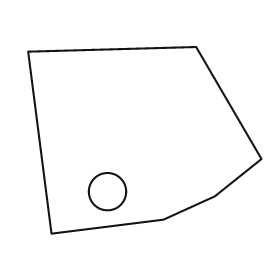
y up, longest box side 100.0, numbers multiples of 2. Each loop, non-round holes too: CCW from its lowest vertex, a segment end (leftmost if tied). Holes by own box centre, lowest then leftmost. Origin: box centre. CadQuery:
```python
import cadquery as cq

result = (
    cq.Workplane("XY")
    .moveTo(-40.0, -40.0)
    .lineTo(8.0, -34.0)
    .lineTo(30.0, -24.0)
    .lineTo(50.0, -8.0)
    .lineTo(22.0, 40.0)
    .lineTo(-50.0, 38.0)
    .close()
    .moveTo(-16.0, -22.0)
    .circle(8.0)
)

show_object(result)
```